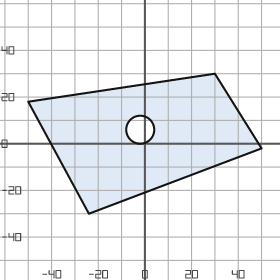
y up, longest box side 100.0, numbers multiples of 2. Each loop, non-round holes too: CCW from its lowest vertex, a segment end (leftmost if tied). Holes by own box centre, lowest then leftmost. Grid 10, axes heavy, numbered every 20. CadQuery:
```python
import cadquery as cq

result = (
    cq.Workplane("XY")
    .moveTo(-24.0, -30.0)
    .lineTo(50.0, -2.0)
    .lineTo(30.0, 30.0)
    .lineTo(-50.0, 18.0)
    .close()
    .moveTo(-2.0, 6.0)
    .circle(6.0)
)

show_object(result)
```